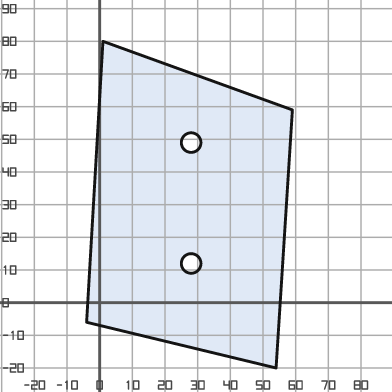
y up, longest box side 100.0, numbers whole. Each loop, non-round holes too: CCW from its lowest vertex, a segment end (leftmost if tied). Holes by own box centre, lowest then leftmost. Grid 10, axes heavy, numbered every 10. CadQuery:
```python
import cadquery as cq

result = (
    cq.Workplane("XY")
    .moveTo(54.0, -20.0)
    .lineTo(59.0, 59.0)
    .lineTo(1.0, 80.0)
    .lineTo(-4.0, -6.0)
    .close()
    .moveTo(28.0, 12.0)
    .circle(3.0)
    .moveTo(28.0, 49.0)
    .circle(3.0)
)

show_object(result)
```